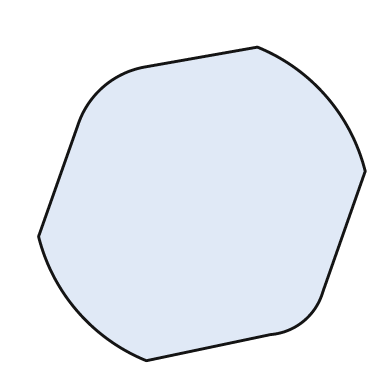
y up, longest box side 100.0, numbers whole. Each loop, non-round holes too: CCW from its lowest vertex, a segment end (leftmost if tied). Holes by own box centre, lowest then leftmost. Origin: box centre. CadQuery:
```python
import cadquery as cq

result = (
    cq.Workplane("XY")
    .moveTo(-17.0, -48.0)
    .lineTo(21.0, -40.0)
    .threePointArc((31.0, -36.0), (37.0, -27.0))
    .lineTo(50.0, 10.0)
    .threePointArc((38.0, 33.0), (17.0, 48.0))
    .lineTo(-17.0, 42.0)
    .threePointArc((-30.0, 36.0), (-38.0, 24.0))
    .lineTo(-50.0, -10.0)
    .threePointArc((-38.0, -33.0), (-17.0, -48.0))
    .close()
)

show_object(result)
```